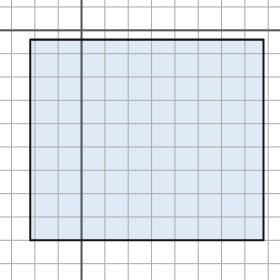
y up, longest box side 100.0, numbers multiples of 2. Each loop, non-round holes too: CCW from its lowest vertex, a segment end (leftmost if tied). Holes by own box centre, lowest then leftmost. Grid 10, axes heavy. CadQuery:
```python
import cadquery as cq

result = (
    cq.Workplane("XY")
    .moveTo(-22.0, -90.0)
    .lineTo(78.0, -90.0)
    .lineTo(78.0, -4.0)
    .lineTo(-22.0, -4.0)
    .close()
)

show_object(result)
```